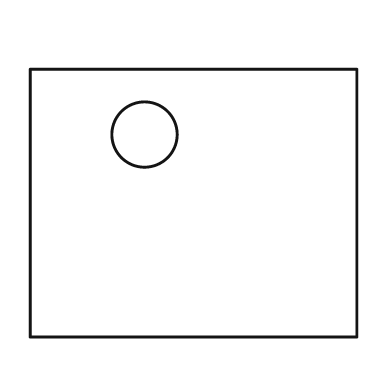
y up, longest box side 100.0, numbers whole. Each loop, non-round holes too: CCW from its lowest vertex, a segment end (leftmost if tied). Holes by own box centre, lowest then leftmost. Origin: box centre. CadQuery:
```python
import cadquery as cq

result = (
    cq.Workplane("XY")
    .moveTo(-50.0, -41.0)
    .lineTo(50.0, -41.0)
    .lineTo(50.0, 41.0)
    .lineTo(-50.0, 41.0)
    .close()
    .moveTo(-15.0, 21.0)
    .circle(10.0)
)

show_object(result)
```